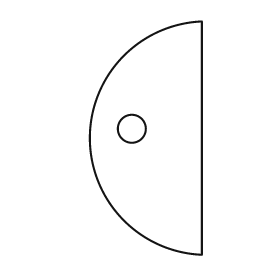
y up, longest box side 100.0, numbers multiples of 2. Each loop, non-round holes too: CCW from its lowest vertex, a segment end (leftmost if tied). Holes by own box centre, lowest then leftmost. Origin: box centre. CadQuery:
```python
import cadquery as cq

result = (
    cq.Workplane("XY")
    .moveTo(24.0, -50.0)
    .lineTo(24.0, 50.0)
    .threePointArc((-24.0, 0.0), (24.0, -50.0))
    .close()
    .moveTo(-6.0, 4.0)
    .circle(6.0)
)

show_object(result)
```